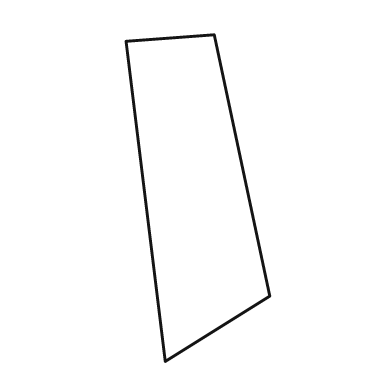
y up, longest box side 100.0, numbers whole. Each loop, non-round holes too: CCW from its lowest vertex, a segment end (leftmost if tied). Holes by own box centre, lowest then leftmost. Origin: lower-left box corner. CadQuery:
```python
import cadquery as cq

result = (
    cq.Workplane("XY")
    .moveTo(12.0, 0.0)
    .lineTo(44.0, 20.0)
    .lineTo(27.0, 100.0)
    .lineTo(0.0, 98.0)
    .close()
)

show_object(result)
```